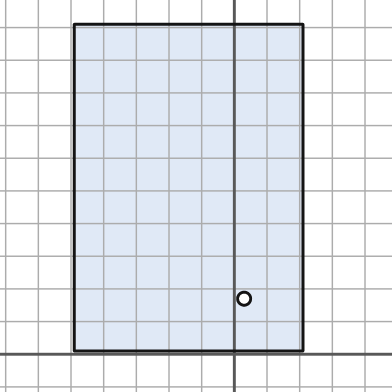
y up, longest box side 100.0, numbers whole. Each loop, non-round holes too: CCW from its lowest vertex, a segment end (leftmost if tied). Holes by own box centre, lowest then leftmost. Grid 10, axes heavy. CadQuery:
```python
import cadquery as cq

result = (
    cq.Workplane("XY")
    .moveTo(-49.0, 1.0)
    .lineTo(21.0, 1.0)
    .lineTo(21.0, 101.0)
    .lineTo(-49.0, 101.0)
    .close()
    .moveTo(3.0, 17.0)
    .circle(2.0)
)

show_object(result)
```